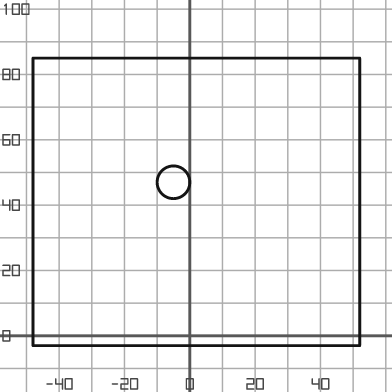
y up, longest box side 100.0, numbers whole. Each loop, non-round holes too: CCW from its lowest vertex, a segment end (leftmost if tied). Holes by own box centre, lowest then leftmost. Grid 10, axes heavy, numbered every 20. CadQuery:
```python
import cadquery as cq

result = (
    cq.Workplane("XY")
    .moveTo(-48.0, -3.0)
    .lineTo(52.0, -3.0)
    .lineTo(52.0, 85.0)
    .lineTo(-48.0, 85.0)
    .close()
    .moveTo(-5.0, 47.0)
    .circle(5.0)
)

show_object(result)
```